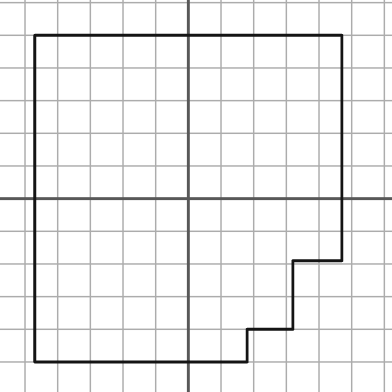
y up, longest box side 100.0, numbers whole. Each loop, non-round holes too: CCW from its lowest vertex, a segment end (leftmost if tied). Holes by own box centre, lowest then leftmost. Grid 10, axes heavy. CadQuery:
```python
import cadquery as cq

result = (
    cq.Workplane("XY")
    .moveTo(-47.0, -50.0)
    .lineTo(18.0, -50.0)
    .lineTo(18.0, -40.0)
    .lineTo(32.0, -40.0)
    .lineTo(32.0, -19.0)
    .lineTo(47.0, -19.0)
    .lineTo(47.0, 50.0)
    .lineTo(-47.0, 50.0)
    .close()
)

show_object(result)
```